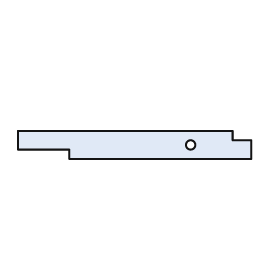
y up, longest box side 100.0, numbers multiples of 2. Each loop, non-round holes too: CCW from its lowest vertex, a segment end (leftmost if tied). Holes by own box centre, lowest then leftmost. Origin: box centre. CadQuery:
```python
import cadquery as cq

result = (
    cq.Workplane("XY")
    .moveTo(-28.0, -6.0)
    .lineTo(50.0, -6.0)
    .lineTo(50.0, 2.0)
    .lineTo(42.0, 2.0)
    .lineTo(42.0, 6.0)
    .lineTo(-50.0, 6.0)
    .lineTo(-50.0, -2.0)
    .lineTo(-28.0, -2.0)
    .close()
    .moveTo(24.0, 0.0)
    .circle(2.0)
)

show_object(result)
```